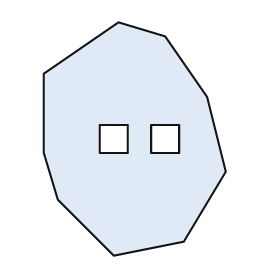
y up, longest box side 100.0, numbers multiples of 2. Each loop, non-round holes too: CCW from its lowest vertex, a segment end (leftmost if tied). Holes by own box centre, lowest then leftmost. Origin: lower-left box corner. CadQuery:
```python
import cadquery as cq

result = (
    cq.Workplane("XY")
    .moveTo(30.0, 0.0)
    .lineTo(60.0, 6.0)
    .lineTo(78.0, 36.0)
    .lineTo(70.0, 68.0)
    .lineTo(52.0, 94.0)
    .lineTo(32.0, 100.0)
    .lineTo(0.0, 78.0)
    .lineTo(0.0, 44.0)
    .lineTo(6.0, 24.0)
    .close()
    .moveTo(24.0, 44.0)
    .lineTo(36.0, 44.0)
    .lineTo(36.0, 56.0)
    .lineTo(24.0, 56.0)
    .close()
    .moveTo(46.0, 44.0)
    .lineTo(58.0, 44.0)
    .lineTo(58.0, 56.0)
    .lineTo(46.0, 56.0)
    .close()
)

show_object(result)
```